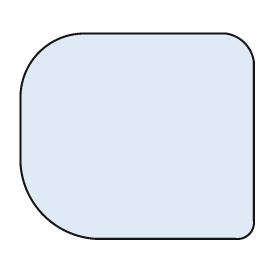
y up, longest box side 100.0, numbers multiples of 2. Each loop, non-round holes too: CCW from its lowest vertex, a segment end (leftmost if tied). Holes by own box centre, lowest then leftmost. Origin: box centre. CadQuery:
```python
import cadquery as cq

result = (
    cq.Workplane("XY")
    .moveTo(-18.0, -44.0)
    .lineTo(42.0, -44.0)
    .threePointArc((48.0, -42.0), (50.0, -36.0))
    .lineTo(50.0, 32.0)
    .threePointArc((46.0, 40.0), (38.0, 44.0))
    .lineTo(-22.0, 44.0)
    .threePointArc((-42.0, 36.0), (-50.0, 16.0))
    .lineTo(-50.0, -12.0)
    .threePointArc((-40.0, -34.0), (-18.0, -44.0))
    .close()
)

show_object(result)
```